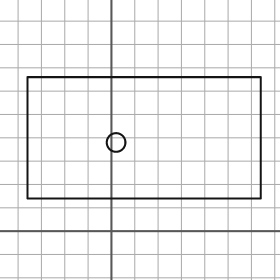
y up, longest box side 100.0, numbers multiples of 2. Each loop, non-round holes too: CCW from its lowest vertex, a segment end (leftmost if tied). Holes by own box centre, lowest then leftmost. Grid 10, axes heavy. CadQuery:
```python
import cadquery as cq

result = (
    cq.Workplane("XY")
    .moveTo(-36.0, 14.0)
    .lineTo(64.0, 14.0)
    .lineTo(64.0, 66.0)
    .lineTo(-36.0, 66.0)
    .close()
    .moveTo(2.0, 38.0)
    .circle(4.0)
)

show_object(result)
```